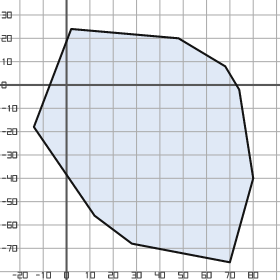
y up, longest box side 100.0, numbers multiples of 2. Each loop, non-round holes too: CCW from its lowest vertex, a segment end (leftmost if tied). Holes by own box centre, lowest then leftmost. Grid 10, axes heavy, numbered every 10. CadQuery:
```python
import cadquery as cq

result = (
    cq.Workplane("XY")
    .moveTo(70.0, -76.0)
    .lineTo(80.0, -40.0)
    .lineTo(74.0, -2.0)
    .lineTo(68.0, 8.0)
    .lineTo(48.0, 20.0)
    .lineTo(2.0, 24.0)
    .lineTo(-14.0, -18.0)
    .lineTo(12.0, -56.0)
    .lineTo(28.0, -68.0)
    .close()
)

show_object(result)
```